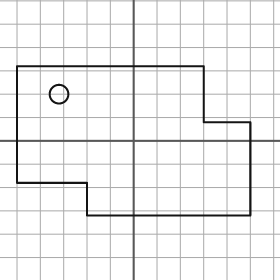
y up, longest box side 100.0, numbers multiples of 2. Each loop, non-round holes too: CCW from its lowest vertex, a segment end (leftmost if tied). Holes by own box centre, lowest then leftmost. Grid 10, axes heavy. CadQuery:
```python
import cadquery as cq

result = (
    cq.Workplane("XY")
    .moveTo(-20.0, -32.0)
    .lineTo(50.0, -32.0)
    .lineTo(50.0, 8.0)
    .lineTo(30.0, 8.0)
    .lineTo(30.0, 32.0)
    .lineTo(-50.0, 32.0)
    .lineTo(-50.0, -18.0)
    .lineTo(-20.0, -18.0)
    .close()
    .moveTo(-32.0, 20.0)
    .circle(4.0)
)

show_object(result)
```